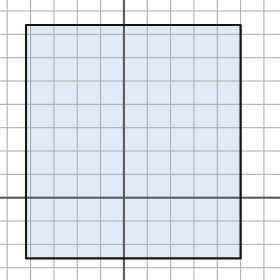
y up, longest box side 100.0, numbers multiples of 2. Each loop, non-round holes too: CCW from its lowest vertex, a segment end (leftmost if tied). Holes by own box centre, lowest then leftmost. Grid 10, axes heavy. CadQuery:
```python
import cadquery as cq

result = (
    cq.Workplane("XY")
    .moveTo(-42.0, -26.0)
    .lineTo(50.0, -26.0)
    .lineTo(50.0, 74.0)
    .lineTo(-42.0, 74.0)
    .close()
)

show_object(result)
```